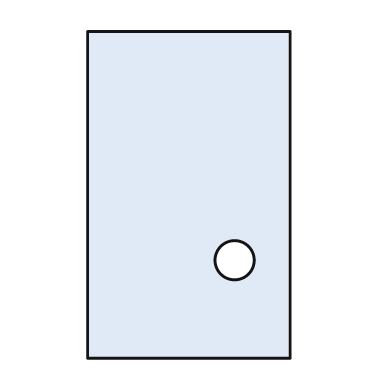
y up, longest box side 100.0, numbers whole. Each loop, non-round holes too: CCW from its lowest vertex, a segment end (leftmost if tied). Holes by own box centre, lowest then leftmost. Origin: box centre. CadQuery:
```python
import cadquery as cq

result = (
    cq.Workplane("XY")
    .moveTo(-31.0, -50.0)
    .lineTo(31.0, -50.0)
    .lineTo(31.0, 50.0)
    .lineTo(-31.0, 50.0)
    .close()
    .moveTo(14.0, -20.0)
    .circle(6.0)
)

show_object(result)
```